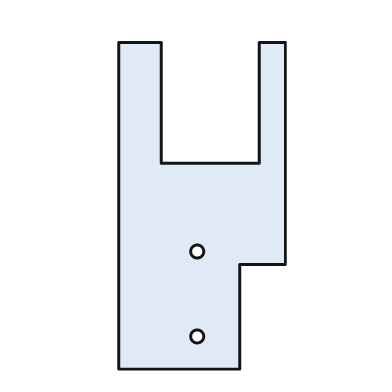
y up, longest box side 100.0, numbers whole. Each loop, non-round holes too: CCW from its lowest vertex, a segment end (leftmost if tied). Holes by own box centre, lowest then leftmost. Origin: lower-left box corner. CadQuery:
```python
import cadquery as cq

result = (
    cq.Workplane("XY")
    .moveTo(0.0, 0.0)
    .lineTo(37.0, 0.0)
    .lineTo(37.0, 32.0)
    .lineTo(51.0, 32.0)
    .lineTo(51.0, 100.0)
    .lineTo(43.0, 100.0)
    .lineTo(43.0, 63.0)
    .lineTo(13.0, 63.0)
    .lineTo(13.0, 100.0)
    .lineTo(0.0, 100.0)
    .close()
    .moveTo(24.0, 10.0)
    .circle(2.0)
    .moveTo(24.0, 36.0)
    .circle(2.0)
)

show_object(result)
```